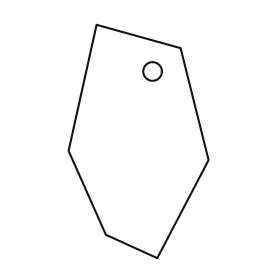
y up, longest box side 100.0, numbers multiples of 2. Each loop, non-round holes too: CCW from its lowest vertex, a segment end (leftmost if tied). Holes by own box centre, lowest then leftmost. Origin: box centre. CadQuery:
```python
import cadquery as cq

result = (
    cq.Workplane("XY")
    .moveTo(8.0, -50.0)
    .lineTo(30.0, -8.0)
    .lineTo(18.0, 40.0)
    .lineTo(-18.0, 50.0)
    .lineTo(-30.0, -4.0)
    .lineTo(-14.0, -40.0)
    .close()
    .moveTo(6.0, 30.0)
    .circle(4.0)
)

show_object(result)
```